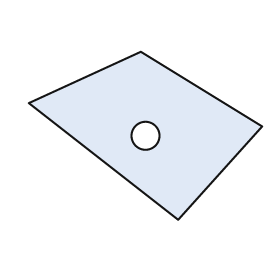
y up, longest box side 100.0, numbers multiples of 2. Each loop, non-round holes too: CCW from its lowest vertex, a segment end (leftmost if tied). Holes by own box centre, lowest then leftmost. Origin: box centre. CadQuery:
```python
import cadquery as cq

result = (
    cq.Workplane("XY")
    .moveTo(14.0, -36.0)
    .lineTo(50.0, 4.0)
    .lineTo(-2.0, 36.0)
    .lineTo(-50.0, 14.0)
    .close()
    .moveTo(0.0, 0.0)
    .circle(6.0)
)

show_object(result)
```